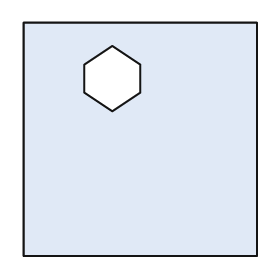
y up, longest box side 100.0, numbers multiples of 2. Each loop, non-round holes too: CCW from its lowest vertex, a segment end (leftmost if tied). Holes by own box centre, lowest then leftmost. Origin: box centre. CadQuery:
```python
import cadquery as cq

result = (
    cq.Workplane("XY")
    .moveTo(-50.0, -50.0)
    .lineTo(50.0, -50.0)
    .lineTo(50.0, 50.0)
    .lineTo(-50.0, 50.0)
    .close()
    .moveTo(-12.0, 12.0)
    .lineTo(0.0, 20.0)
    .lineTo(0.0, 32.0)
    .lineTo(-12.0, 40.0)
    .lineTo(-24.0, 32.0)
    .lineTo(-24.0, 20.0)
    .close()
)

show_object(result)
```